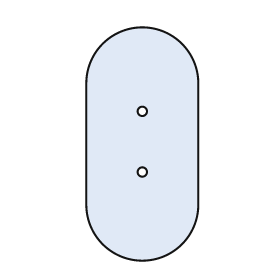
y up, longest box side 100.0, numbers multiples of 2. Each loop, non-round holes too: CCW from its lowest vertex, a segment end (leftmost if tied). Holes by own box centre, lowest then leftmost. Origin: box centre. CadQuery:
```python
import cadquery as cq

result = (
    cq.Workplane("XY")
    .moveTo(-24.0, -26.0)
    .threePointArc((0.0, -50.0), (24.0, -26.0))
    .lineTo(24.0, 26.0)
    .threePointArc((0.0, 50.0), (-24.0, 26.0))
    .close()
    .moveTo(0.0, -12.0)
    .circle(2.0)
    .moveTo(0.0, 14.0)
    .circle(2.0)
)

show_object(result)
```